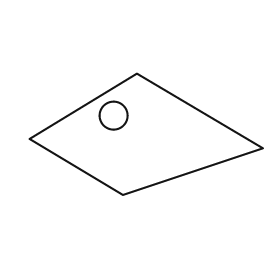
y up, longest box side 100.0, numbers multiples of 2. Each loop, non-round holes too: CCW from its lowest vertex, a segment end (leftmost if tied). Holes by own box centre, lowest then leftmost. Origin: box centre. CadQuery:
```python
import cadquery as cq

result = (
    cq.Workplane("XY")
    .moveTo(-10.0, -26.0)
    .lineTo(50.0, -6.0)
    .lineTo(-4.0, 26.0)
    .lineTo(-50.0, -2.0)
    .close()
    .moveTo(-14.0, 8.0)
    .circle(6.0)
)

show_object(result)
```